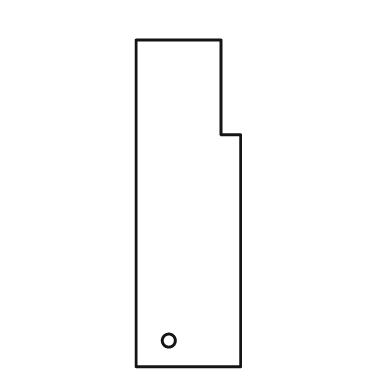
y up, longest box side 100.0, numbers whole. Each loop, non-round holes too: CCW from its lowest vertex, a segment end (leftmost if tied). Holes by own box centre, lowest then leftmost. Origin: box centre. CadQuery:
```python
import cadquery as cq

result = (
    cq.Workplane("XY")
    .moveTo(-16.0, -50.0)
    .lineTo(16.0, -50.0)
    .lineTo(16.0, 21.0)
    .lineTo(10.0, 21.0)
    .lineTo(10.0, 50.0)
    .lineTo(-16.0, 50.0)
    .close()
    .moveTo(-6.0, -42.0)
    .circle(2.0)
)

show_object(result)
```